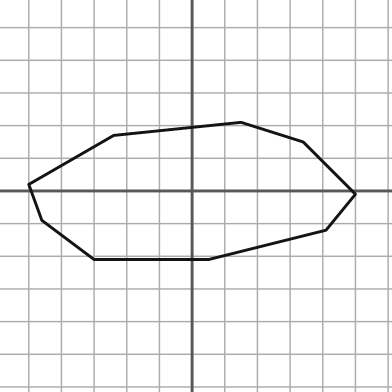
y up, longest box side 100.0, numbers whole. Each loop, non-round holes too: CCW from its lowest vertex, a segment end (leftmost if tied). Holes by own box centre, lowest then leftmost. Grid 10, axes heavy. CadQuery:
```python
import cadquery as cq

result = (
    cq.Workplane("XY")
    .moveTo(-30.0, -21.0)
    .lineTo(5.0, -21.0)
    .lineTo(41.0, -12.0)
    .lineTo(50.0, -1.0)
    .lineTo(34.0, 15.0)
    .lineTo(15.0, 21.0)
    .lineTo(-24.0, 17.0)
    .lineTo(-50.0, 2.0)
    .lineTo(-46.0, -9.0)
    .close()
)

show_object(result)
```